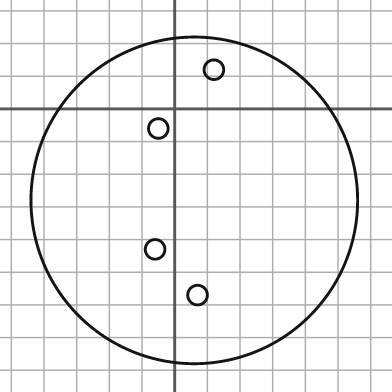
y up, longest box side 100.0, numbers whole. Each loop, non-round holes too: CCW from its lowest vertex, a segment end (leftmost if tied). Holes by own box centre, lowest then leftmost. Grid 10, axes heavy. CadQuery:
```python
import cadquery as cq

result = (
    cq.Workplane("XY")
    .moveTo(6.0, -28.0)
    .circle(50.0)
    .moveTo(7.0, -57.0)
    .circle(3.0)
    .moveTo(-6.0, -43.0)
    .circle(3.0)
    .moveTo(-5.0, -6.0)
    .circle(3.0)
    .moveTo(12.0, 12.0)
    .circle(3.0)
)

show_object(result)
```